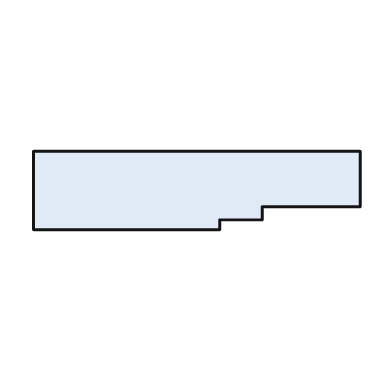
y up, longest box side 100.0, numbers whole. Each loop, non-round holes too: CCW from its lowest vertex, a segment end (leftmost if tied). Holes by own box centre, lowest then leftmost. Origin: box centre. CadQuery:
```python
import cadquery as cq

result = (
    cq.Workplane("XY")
    .moveTo(-50.0, -12.0)
    .lineTo(7.0, -12.0)
    .lineTo(7.0, -9.0)
    .lineTo(20.0, -9.0)
    .lineTo(20.0, -5.0)
    .lineTo(50.0, -5.0)
    .lineTo(50.0, 12.0)
    .lineTo(-50.0, 12.0)
    .close()
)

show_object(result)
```